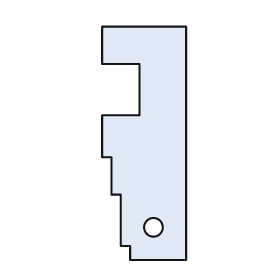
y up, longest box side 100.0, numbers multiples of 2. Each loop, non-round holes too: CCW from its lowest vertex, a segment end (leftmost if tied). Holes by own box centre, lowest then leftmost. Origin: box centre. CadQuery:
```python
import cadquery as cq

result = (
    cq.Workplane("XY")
    .moveTo(-6.0, -50.0)
    .lineTo(18.0, -50.0)
    .lineTo(18.0, 50.0)
    .lineTo(-18.0, 50.0)
    .lineTo(-18.0, 34.0)
    .lineTo(-2.0, 34.0)
    .lineTo(-2.0, 12.0)
    .lineTo(-18.0, 12.0)
    .lineTo(-18.0, -6.0)
    .lineTo(-14.0, -6.0)
    .lineTo(-14.0, -22.0)
    .lineTo(-10.0, -22.0)
    .lineTo(-10.0, -44.0)
    .lineTo(-6.0, -44.0)
    .close()
    .moveTo(4.0, -36.0)
    .circle(4.0)
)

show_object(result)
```